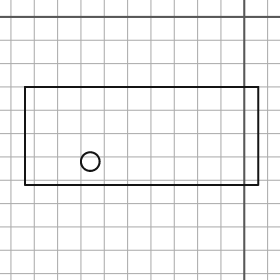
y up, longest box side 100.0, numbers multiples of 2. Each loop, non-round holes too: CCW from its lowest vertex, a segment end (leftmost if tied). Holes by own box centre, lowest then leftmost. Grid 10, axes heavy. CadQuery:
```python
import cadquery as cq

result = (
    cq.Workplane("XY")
    .moveTo(-94.0, -72.0)
    .lineTo(6.0, -72.0)
    .lineTo(6.0, -30.0)
    .lineTo(-94.0, -30.0)
    .close()
    .moveTo(-66.0, -62.0)
    .circle(4.0)
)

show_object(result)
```